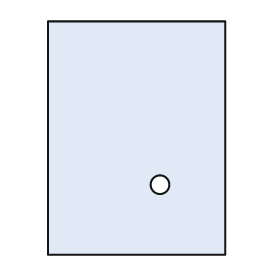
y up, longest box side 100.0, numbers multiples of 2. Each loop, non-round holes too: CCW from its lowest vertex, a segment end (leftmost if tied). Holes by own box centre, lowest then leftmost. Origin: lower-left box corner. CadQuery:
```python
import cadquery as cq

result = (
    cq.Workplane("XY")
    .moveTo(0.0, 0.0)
    .lineTo(76.0, 0.0)
    .lineTo(76.0, 100.0)
    .lineTo(0.0, 100.0)
    .close()
    .moveTo(48.0, 30.0)
    .circle(4.0)
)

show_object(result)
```